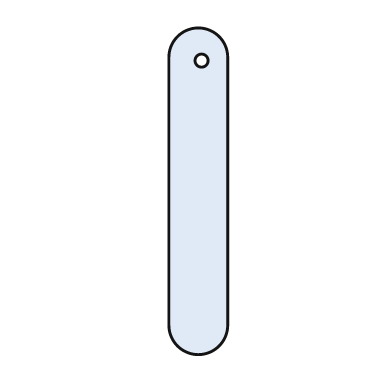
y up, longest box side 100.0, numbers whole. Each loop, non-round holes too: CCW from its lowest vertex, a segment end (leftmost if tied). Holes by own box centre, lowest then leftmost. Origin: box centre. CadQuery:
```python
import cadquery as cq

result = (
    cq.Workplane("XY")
    .moveTo(-9.0, -41.0)
    .threePointArc((0.0, -50.0), (9.0, -41.0))
    .lineTo(9.0, 41.0)
    .threePointArc((0.0, 50.0), (-9.0, 41.0))
    .close()
    .moveTo(1.0, 40.0)
    .circle(2.0)
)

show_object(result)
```